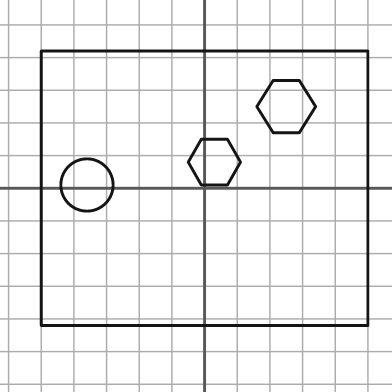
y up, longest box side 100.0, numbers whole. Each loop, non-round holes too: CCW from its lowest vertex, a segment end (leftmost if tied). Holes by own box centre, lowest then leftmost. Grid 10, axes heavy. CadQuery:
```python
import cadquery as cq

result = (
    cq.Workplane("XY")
    .moveTo(-50.0, -42.0)
    .lineTo(50.0, -42.0)
    .lineTo(50.0, 42.0)
    .lineTo(-50.0, 42.0)
    .close()
    .moveTo(-36.0, 1.0)
    .circle(8.0)
    .moveTo(-1.0, 1.0)
    .lineTo(7.0, 1.0)
    .lineTo(11.0, 8.0)
    .lineTo(7.0, 15.0)
    .lineTo(-1.0, 15.0)
    .lineTo(-5.0, 8.0)
    .close()
    .moveTo(21.0, 17.0)
    .lineTo(29.0, 17.0)
    .lineTo(34.0, 25.0)
    .lineTo(29.0, 33.0)
    .lineTo(21.0, 33.0)
    .lineTo(16.0, 25.0)
    .close()
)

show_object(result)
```